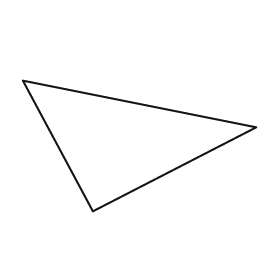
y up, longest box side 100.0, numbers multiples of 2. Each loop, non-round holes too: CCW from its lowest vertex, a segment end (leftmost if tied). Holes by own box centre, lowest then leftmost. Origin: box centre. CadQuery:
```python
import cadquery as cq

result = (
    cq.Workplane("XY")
    .moveTo(-20.0, -28.0)
    .lineTo(50.0, 8.0)
    .lineTo(-50.0, 28.0)
    .close()
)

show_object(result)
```